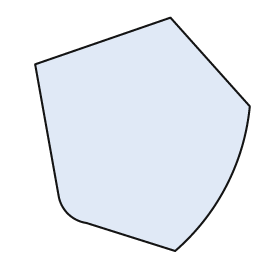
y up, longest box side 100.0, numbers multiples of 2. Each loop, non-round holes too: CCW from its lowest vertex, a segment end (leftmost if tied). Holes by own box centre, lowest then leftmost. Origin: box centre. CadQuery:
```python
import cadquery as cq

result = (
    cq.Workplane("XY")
    .moveTo(14.0, -50.0)
    .threePointArc((36.0, -22.0), (46.0, 12.0))
    .lineTo(12.0, 50.0)
    .lineTo(-46.0, 30.0)
    .lineTo(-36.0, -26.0)
    .threePointArc((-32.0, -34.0), (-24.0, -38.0))
    .close()
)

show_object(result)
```